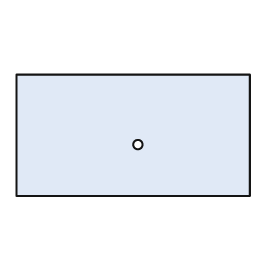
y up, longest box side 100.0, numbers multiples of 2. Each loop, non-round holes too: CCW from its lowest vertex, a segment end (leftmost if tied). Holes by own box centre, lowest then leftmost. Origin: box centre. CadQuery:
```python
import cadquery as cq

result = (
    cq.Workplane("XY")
    .moveTo(-50.0, -26.0)
    .lineTo(50.0, -26.0)
    .lineTo(50.0, 26.0)
    .lineTo(-50.0, 26.0)
    .close()
    .moveTo(2.0, -4.0)
    .circle(2.0)
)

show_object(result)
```